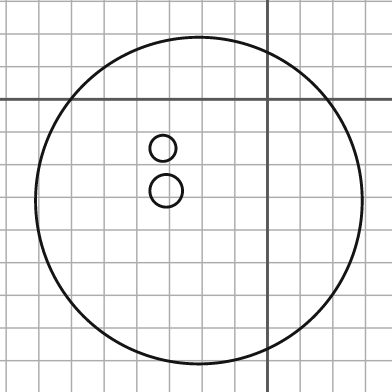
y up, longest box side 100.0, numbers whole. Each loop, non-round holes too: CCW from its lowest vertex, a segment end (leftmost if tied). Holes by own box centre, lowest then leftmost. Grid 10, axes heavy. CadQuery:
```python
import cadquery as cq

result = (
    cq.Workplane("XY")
    .moveTo(-21.0, -31.0)
    .circle(50.0)
    .moveTo(-31.0, -28.0)
    .circle(5.0)
    .moveTo(-32.0, -15.0)
    .circle(4.0)
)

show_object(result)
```